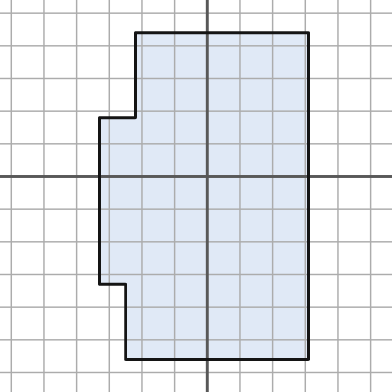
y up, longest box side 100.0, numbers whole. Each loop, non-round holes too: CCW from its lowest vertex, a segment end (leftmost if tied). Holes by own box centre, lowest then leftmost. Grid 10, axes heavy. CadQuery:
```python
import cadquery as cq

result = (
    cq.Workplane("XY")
    .moveTo(-25.0, -56.0)
    .lineTo(31.0, -56.0)
    .lineTo(31.0, 44.0)
    .lineTo(-22.0, 44.0)
    .lineTo(-22.0, 18.0)
    .lineTo(-33.0, 18.0)
    .lineTo(-33.0, -33.0)
    .lineTo(-25.0, -33.0)
    .close()
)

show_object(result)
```